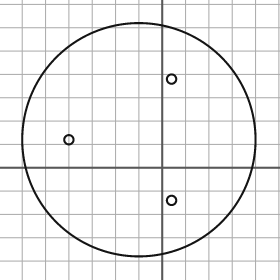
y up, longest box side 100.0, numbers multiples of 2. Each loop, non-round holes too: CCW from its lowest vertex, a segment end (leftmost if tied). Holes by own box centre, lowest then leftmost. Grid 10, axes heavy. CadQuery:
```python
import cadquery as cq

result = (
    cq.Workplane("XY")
    .moveTo(-10.0, 12.0)
    .circle(50.0)
    .moveTo(4.0, -14.0)
    .circle(2.0)
    .moveTo(-40.0, 12.0)
    .circle(2.0)
    .moveTo(4.0, 38.0)
    .circle(2.0)
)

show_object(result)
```